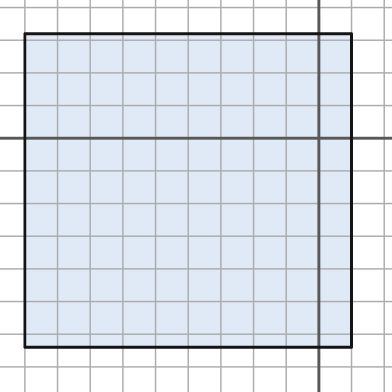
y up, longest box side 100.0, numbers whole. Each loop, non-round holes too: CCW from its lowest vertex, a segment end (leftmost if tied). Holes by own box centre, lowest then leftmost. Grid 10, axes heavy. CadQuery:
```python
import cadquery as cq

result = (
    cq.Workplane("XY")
    .moveTo(-90.0, -64.0)
    .lineTo(10.0, -64.0)
    .lineTo(10.0, 32.0)
    .lineTo(-90.0, 32.0)
    .close()
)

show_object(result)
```